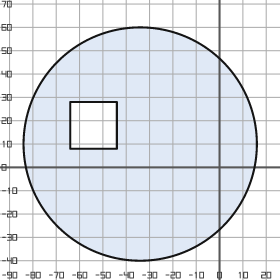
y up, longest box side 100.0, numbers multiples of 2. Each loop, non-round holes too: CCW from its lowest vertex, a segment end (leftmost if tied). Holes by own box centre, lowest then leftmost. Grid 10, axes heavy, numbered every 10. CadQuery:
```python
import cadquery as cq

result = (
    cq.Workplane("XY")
    .moveTo(-34.0, 10.0)
    .circle(50.0)
    .moveTo(-64.0, 8.0)
    .lineTo(-44.0, 8.0)
    .lineTo(-44.0, 28.0)
    .lineTo(-64.0, 28.0)
    .close()
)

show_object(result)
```